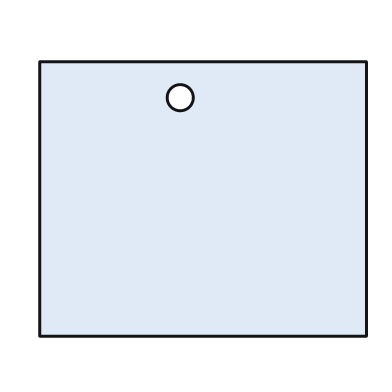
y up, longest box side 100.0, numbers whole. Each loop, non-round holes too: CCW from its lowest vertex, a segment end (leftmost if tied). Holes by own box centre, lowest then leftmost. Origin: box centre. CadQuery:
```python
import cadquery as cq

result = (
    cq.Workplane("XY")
    .moveTo(-50.0, -42.0)
    .lineTo(50.0, -42.0)
    .lineTo(50.0, 42.0)
    .lineTo(-50.0, 42.0)
    .close()
    .moveTo(-7.0, 31.0)
    .circle(4.0)
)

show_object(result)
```